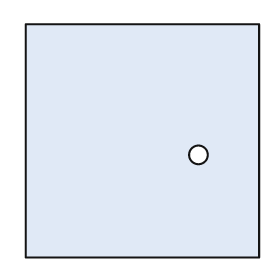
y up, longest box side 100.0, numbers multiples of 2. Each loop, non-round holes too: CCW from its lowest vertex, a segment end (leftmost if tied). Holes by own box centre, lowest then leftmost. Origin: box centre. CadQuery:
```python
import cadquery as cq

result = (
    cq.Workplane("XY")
    .moveTo(-50.0, -50.0)
    .lineTo(50.0, -50.0)
    .lineTo(50.0, 50.0)
    .lineTo(-50.0, 50.0)
    .close()
    .moveTo(24.0, -6.0)
    .circle(4.0)
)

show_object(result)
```